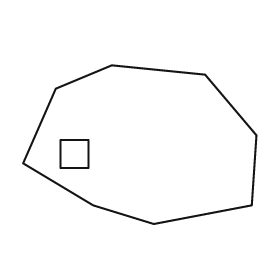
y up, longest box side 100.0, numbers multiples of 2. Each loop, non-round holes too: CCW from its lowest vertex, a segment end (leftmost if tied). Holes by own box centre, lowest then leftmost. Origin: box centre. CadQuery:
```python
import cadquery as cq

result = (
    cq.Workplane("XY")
    .moveTo(6.0, -34.0)
    .lineTo(48.0, -26.0)
    .lineTo(50.0, 4.0)
    .lineTo(28.0, 30.0)
    .lineTo(-12.0, 34.0)
    .lineTo(-36.0, 24.0)
    .lineTo(-50.0, -8.0)
    .lineTo(-20.0, -26.0)
    .close()
    .moveTo(-34.0, -10.0)
    .lineTo(-22.0, -10.0)
    .lineTo(-22.0, 2.0)
    .lineTo(-34.0, 2.0)
    .close()
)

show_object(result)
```